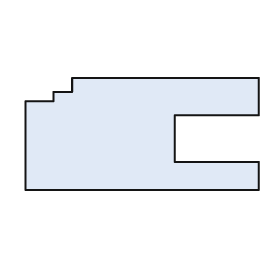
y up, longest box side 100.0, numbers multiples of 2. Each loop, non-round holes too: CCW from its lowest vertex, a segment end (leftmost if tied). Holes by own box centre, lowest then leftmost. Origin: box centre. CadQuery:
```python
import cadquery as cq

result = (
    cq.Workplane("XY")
    .moveTo(-50.0, -24.0)
    .lineTo(50.0, -24.0)
    .lineTo(50.0, -12.0)
    .lineTo(14.0, -12.0)
    .lineTo(14.0, 8.0)
    .lineTo(50.0, 8.0)
    .lineTo(50.0, 24.0)
    .lineTo(-30.0, 24.0)
    .lineTo(-30.0, 18.0)
    .lineTo(-38.0, 18.0)
    .lineTo(-38.0, 14.0)
    .lineTo(-50.0, 14.0)
    .close()
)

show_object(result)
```